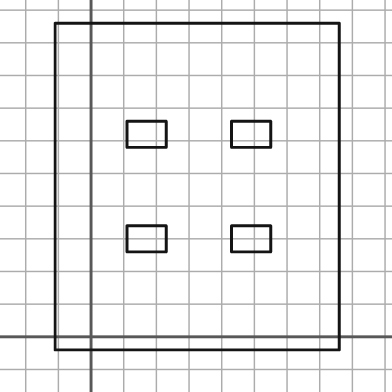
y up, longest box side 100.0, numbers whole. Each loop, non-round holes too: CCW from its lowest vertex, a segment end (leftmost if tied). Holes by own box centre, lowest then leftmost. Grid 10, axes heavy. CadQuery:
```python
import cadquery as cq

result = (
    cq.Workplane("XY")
    .moveTo(-11.0, -4.0)
    .lineTo(76.0, -4.0)
    .lineTo(76.0, 96.0)
    .lineTo(-11.0, 96.0)
    .close()
    .moveTo(11.0, 26.0)
    .lineTo(23.0, 26.0)
    .lineTo(23.0, 34.0)
    .lineTo(11.0, 34.0)
    .close()
    .moveTo(43.0, 26.0)
    .lineTo(55.0, 26.0)
    .lineTo(55.0, 34.0)
    .lineTo(43.0, 34.0)
    .close()
    .moveTo(11.0, 58.0)
    .lineTo(23.0, 58.0)
    .lineTo(23.0, 66.0)
    .lineTo(11.0, 66.0)
    .close()
    .moveTo(43.0, 58.0)
    .lineTo(55.0, 58.0)
    .lineTo(55.0, 66.0)
    .lineTo(43.0, 66.0)
    .close()
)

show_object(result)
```